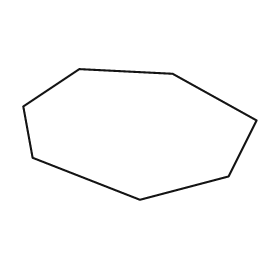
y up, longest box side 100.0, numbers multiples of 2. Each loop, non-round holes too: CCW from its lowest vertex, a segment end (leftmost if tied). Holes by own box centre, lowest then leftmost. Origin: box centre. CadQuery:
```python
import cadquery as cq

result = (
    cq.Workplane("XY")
    .moveTo(0.0, -28.0)
    .lineTo(38.0, -18.0)
    .lineTo(50.0, 6.0)
    .lineTo(14.0, 26.0)
    .lineTo(-26.0, 28.0)
    .lineTo(-50.0, 12.0)
    .lineTo(-46.0, -10.0)
    .close()
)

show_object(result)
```